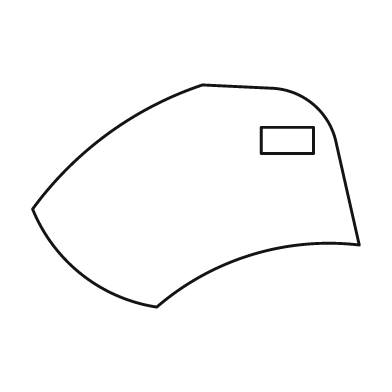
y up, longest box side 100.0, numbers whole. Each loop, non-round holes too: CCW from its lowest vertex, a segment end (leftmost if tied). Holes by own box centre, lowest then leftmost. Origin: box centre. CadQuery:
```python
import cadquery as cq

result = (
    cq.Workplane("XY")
    .moveTo(-12.0, -34.0)
    .threePointArc((17.0, -18.0), (50.0, -15.0))
    .lineTo(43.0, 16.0)
    .threePointArc((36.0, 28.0), (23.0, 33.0))
    .lineTo(2.0, 34.0)
    .threePointArc((-27.0, 19.0), (-50.0, -4.0))
    .threePointArc((-35.0, -24.0), (-12.0, -34.0))
    .close()
    .moveTo(20.0, 13.0)
    .lineTo(36.0, 13.0)
    .lineTo(36.0, 21.0)
    .lineTo(20.0, 21.0)
    .close()
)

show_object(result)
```